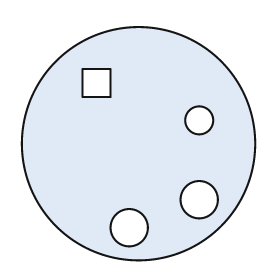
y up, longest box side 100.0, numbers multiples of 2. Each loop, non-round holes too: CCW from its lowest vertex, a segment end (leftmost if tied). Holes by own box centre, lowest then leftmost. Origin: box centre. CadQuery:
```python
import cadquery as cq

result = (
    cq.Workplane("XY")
    .moveTo(0.0, 0.0)
    .circle(50.0)
    .moveTo(-4.0, -36.0)
    .circle(8.0)
    .moveTo(26.0, -24.0)
    .circle(8.0)
    .moveTo(26.0, 10.0)
    .circle(6.0)
    .moveTo(-24.0, 20.0)
    .lineTo(-12.0, 20.0)
    .lineTo(-12.0, 32.0)
    .lineTo(-24.0, 32.0)
    .close()
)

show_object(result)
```